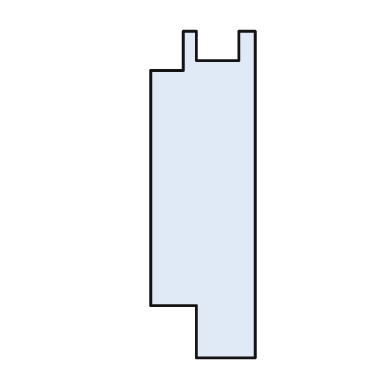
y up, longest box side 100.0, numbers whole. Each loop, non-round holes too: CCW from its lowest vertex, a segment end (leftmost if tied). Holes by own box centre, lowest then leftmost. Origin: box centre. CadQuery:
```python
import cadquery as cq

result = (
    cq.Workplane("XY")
    .moveTo(-2.0, -50.0)
    .lineTo(16.0, -50.0)
    .lineTo(16.0, 50.0)
    .lineTo(11.0, 50.0)
    .lineTo(11.0, 41.0)
    .lineTo(-2.0, 41.0)
    .lineTo(-2.0, 50.0)
    .lineTo(-6.0, 50.0)
    .lineTo(-6.0, 38.0)
    .lineTo(-16.0, 38.0)
    .lineTo(-16.0, -34.0)
    .lineTo(-2.0, -34.0)
    .close()
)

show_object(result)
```